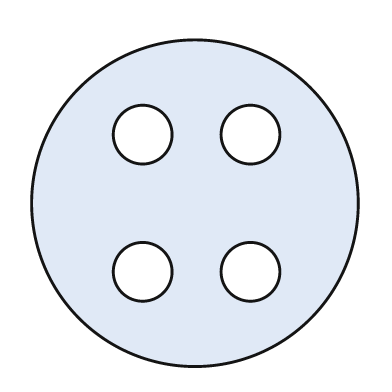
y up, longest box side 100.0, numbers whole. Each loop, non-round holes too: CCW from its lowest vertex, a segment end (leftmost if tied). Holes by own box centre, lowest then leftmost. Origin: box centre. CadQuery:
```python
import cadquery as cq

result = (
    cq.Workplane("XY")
    .moveTo(0.0, 0.0)
    .circle(50.0)
    .moveTo(-16.0, -21.0)
    .circle(9.0)
    .moveTo(17.0, -21.0)
    .circle(9.0)
    .moveTo(-16.0, 21.0)
    .circle(9.0)
    .moveTo(17.0, 21.0)
    .circle(9.0)
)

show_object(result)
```